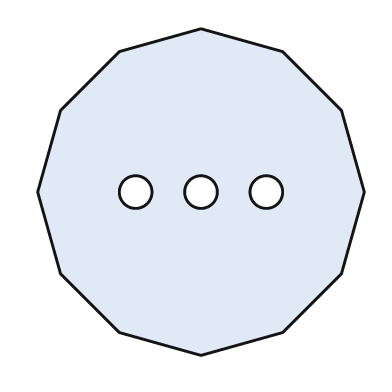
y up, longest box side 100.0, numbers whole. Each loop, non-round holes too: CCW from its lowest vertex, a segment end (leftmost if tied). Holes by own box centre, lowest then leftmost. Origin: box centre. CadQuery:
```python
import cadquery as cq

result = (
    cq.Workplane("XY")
    .moveTo(0.0, -50.0)
    .lineTo(25.0, -43.0)
    .lineTo(43.0, -25.0)
    .lineTo(50.0, 0.0)
    .lineTo(43.0, 25.0)
    .lineTo(25.0, 43.0)
    .lineTo(0.0, 50.0)
    .lineTo(-25.0, 43.0)
    .lineTo(-43.0, 25.0)
    .lineTo(-50.0, 0.0)
    .lineTo(-43.0, -25.0)
    .lineTo(-25.0, -43.0)
    .close()
    .moveTo(-20.0, 0.0)
    .circle(5.0)
    .moveTo(0.0, 0.0)
    .circle(5.0)
    .moveTo(20.0, 0.0)
    .circle(5.0)
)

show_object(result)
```